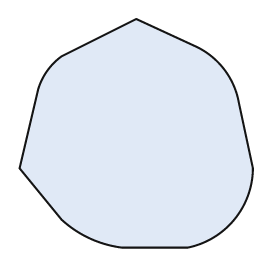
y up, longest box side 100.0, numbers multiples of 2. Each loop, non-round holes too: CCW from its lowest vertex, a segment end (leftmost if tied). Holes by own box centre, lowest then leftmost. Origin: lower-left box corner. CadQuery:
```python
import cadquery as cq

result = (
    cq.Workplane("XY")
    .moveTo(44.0, 0.0)
    .lineTo(72.0, 0.0)
    .threePointArc((92.0, 12.0), (100.0, 34.0))
    .lineTo(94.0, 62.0)
    .threePointArc((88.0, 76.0), (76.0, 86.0))
    .lineTo(50.0, 98.0)
    .lineTo(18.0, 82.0)
    .threePointArc((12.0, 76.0), (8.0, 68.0))
    .lineTo(0.0, 34.0)
    .lineTo(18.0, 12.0)
    .threePointArc((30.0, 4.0), (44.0, 0.0))
    .close()
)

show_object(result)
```